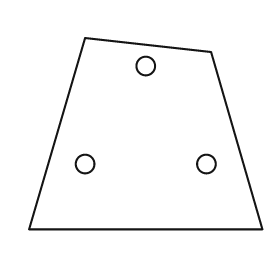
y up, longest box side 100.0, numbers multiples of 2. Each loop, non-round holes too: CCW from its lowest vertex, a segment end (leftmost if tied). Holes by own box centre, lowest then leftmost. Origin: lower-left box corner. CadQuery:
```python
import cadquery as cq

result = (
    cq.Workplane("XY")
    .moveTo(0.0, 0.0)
    .lineTo(100.0, 0.0)
    .lineTo(78.0, 76.0)
    .lineTo(24.0, 82.0)
    .close()
    .moveTo(24.0, 28.0)
    .circle(4.0)
    .moveTo(76.0, 28.0)
    .circle(4.0)
    .moveTo(50.0, 70.0)
    .circle(4.0)
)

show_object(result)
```